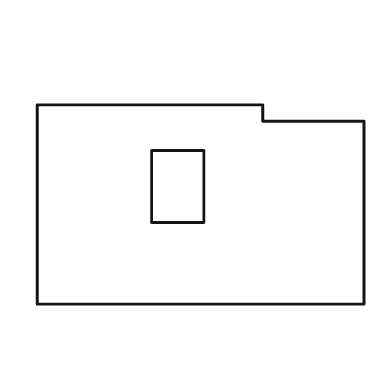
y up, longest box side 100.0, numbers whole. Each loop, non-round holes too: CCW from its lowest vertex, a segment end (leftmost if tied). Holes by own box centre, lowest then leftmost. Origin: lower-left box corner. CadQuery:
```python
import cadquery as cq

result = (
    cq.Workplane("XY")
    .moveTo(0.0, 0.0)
    .lineTo(100.0, 0.0)
    .lineTo(100.0, 56.0)
    .lineTo(69.0, 56.0)
    .lineTo(69.0, 61.0)
    .lineTo(0.0, 61.0)
    .close()
    .moveTo(35.0, 25.0)
    .lineTo(51.0, 25.0)
    .lineTo(51.0, 47.0)
    .lineTo(35.0, 47.0)
    .close()
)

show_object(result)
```